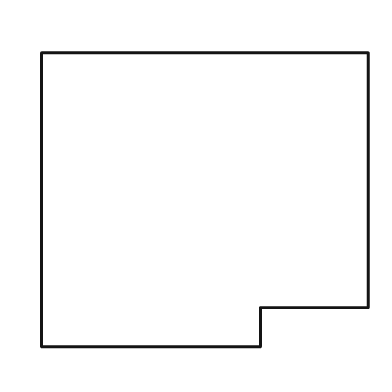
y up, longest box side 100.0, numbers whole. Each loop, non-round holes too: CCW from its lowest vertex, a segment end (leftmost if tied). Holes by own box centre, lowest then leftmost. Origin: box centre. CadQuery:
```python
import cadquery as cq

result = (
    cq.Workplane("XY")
    .moveTo(-50.0, -45.0)
    .lineTo(17.0, -45.0)
    .lineTo(17.0, -33.0)
    .lineTo(50.0, -33.0)
    .lineTo(50.0, 45.0)
    .lineTo(-50.0, 45.0)
    .close()
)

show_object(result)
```